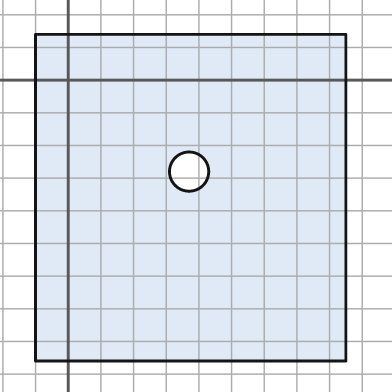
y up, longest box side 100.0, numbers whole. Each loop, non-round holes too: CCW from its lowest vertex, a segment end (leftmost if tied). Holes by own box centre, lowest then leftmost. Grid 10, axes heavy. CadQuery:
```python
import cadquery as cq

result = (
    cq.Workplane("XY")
    .moveTo(-10.0, -86.0)
    .lineTo(85.0, -86.0)
    .lineTo(85.0, 14.0)
    .lineTo(-10.0, 14.0)
    .close()
    .moveTo(37.0, -28.0)
    .circle(6.0)
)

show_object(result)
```